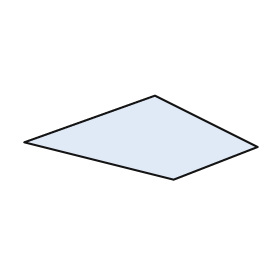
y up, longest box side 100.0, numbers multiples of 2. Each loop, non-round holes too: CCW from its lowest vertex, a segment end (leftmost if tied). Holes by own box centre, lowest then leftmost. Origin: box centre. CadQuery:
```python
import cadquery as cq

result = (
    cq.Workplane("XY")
    .moveTo(14.0, -18.0)
    .lineTo(50.0, -4.0)
    .lineTo(6.0, 18.0)
    .lineTo(-50.0, -2.0)
    .close()
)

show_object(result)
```